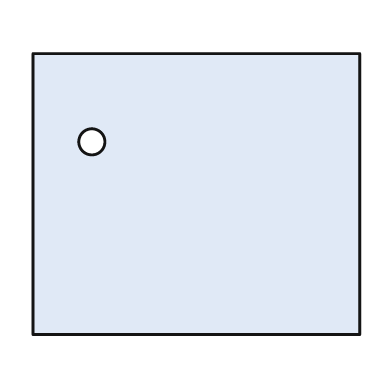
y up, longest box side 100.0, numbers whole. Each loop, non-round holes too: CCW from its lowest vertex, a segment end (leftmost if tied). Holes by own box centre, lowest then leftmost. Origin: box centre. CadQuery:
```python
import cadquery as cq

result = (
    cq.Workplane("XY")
    .moveTo(-50.0, -43.0)
    .lineTo(50.0, -43.0)
    .lineTo(50.0, 43.0)
    .lineTo(-50.0, 43.0)
    .close()
    .moveTo(-32.0, 16.0)
    .circle(4.0)
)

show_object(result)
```